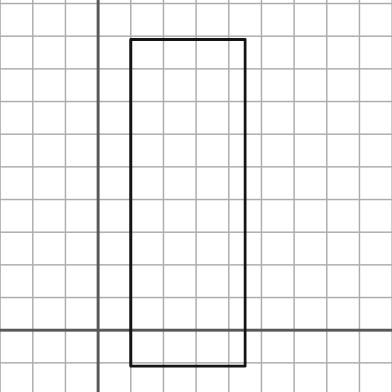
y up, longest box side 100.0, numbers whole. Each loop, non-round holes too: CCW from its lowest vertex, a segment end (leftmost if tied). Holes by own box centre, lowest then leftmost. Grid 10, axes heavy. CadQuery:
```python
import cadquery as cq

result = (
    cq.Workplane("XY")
    .moveTo(10.0, -11.0)
    .lineTo(45.0, -11.0)
    .lineTo(45.0, 89.0)
    .lineTo(10.0, 89.0)
    .close()
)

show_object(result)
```